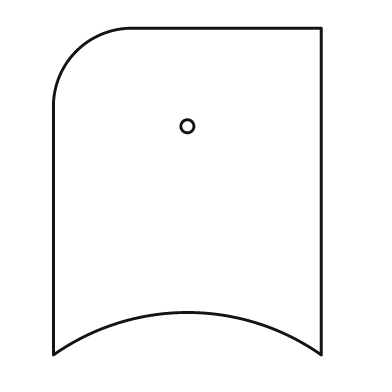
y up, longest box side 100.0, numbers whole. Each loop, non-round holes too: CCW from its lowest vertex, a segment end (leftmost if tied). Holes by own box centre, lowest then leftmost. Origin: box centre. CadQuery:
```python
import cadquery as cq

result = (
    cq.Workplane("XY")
    .moveTo(-41.0, -50.0)
    .threePointArc((0.0, -37.0), (41.0, -50.0))
    .lineTo(41.0, 50.0)
    .lineTo(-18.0, 50.0)
    .threePointArc((-34.0, 43.0), (-41.0, 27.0))
    .close()
    .moveTo(0.0, 20.0)
    .circle(2.0)
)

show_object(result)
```